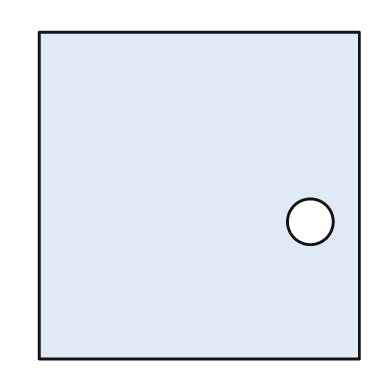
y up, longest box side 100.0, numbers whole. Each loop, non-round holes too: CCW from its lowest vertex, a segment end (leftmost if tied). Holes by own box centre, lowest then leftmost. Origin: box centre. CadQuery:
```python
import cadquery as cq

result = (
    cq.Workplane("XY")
    .moveTo(-49.0, -50.0)
    .lineTo(49.0, -50.0)
    .lineTo(49.0, 50.0)
    .lineTo(-49.0, 50.0)
    .close()
    .moveTo(34.0, -8.0)
    .circle(7.0)
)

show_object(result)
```